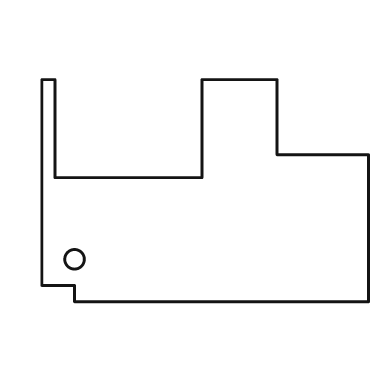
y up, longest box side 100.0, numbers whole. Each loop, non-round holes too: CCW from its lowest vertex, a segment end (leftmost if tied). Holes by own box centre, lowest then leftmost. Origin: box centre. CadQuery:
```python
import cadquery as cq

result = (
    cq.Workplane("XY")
    .moveTo(-40.0, -34.0)
    .lineTo(50.0, -34.0)
    .lineTo(50.0, 11.0)
    .lineTo(22.0, 11.0)
    .lineTo(22.0, 34.0)
    .lineTo(-1.0, 34.0)
    .lineTo(-1.0, 4.0)
    .lineTo(-46.0, 4.0)
    .lineTo(-46.0, 34.0)
    .lineTo(-50.0, 34.0)
    .lineTo(-50.0, -29.0)
    .lineTo(-40.0, -29.0)
    .close()
    .moveTo(-40.0, -21.0)
    .circle(3.0)
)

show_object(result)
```